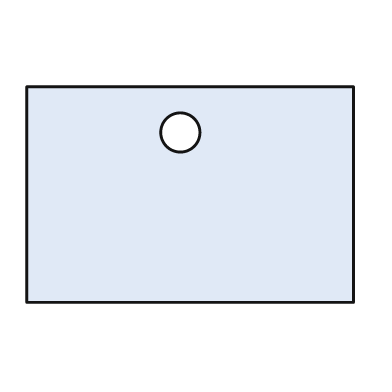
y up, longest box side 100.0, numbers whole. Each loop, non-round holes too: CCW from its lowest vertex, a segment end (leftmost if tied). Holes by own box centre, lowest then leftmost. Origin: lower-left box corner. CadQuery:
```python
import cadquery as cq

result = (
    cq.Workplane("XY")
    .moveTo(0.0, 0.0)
    .lineTo(100.0, 0.0)
    .lineTo(100.0, 66.0)
    .lineTo(0.0, 66.0)
    .close()
    .moveTo(47.0, 52.0)
    .circle(6.0)
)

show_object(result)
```